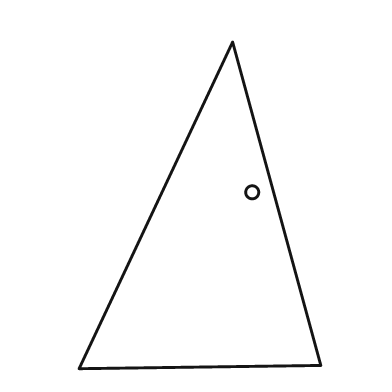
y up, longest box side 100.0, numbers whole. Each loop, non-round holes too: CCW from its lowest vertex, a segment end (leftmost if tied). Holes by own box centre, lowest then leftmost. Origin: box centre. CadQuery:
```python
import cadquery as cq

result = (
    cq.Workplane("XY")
    .moveTo(-37.0, -50.0)
    .lineTo(37.0, -49.0)
    .lineTo(10.0, 50.0)
    .close()
    .moveTo(16.0, 4.0)
    .circle(2.0)
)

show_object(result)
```